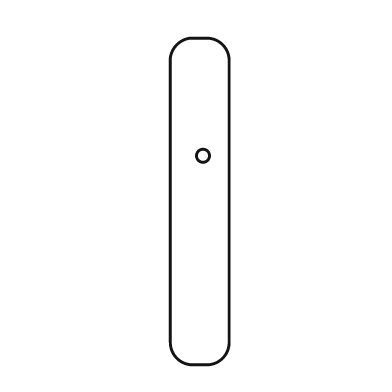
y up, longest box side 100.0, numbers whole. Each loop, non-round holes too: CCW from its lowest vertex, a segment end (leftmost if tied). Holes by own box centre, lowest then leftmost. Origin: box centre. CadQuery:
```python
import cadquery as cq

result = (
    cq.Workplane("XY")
    .moveTo(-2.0, -50.0)
    .lineTo(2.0, -50.0)
    .threePointArc((7.0, -48.0), (9.0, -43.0))
    .lineTo(9.0, 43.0)
    .threePointArc((7.0, 48.0), (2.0, 50.0))
    .lineTo(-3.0, 50.0)
    .threePointArc((-7.0, 48.0), (-9.0, 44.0))
    .lineTo(-9.0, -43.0)
    .threePointArc((-7.0, -48.0), (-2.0, -50.0))
    .close()
    .moveTo(1.0, 14.0)
    .circle(2.0)
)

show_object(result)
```